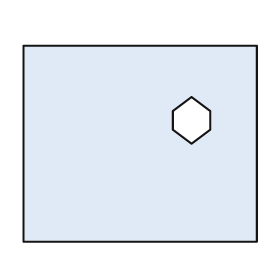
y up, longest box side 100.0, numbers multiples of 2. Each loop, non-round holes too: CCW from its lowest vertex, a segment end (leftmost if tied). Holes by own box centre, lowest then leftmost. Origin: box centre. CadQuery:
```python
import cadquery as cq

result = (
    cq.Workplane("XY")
    .moveTo(-50.0, -42.0)
    .lineTo(50.0, -42.0)
    .lineTo(50.0, 42.0)
    .lineTo(-50.0, 42.0)
    .close()
    .moveTo(22.0, 0.0)
    .lineTo(30.0, 6.0)
    .lineTo(30.0, 14.0)
    .lineTo(22.0, 20.0)
    .lineTo(14.0, 14.0)
    .lineTo(14.0, 6.0)
    .close()
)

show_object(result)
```